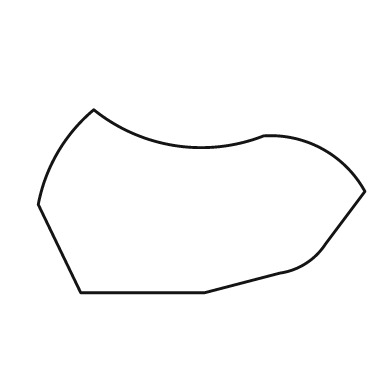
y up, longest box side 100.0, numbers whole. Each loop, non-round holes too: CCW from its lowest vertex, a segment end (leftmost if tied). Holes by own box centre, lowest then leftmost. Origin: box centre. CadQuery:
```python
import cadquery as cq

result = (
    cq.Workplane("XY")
    .moveTo(-37.0, -28.0)
    .lineTo(1.0, -28.0)
    .lineTo(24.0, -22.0)
    .threePointArc((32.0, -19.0), (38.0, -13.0))
    .lineTo(50.0, 3.0)
    .threePointArc((37.0, 16.0), (19.0, 20.0))
    .threePointArc((-8.0, 17.0), (-33.0, 28.0))
    .threePointArc((-44.0, 15.0), (-50.0, -1.0))
    .close()
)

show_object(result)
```